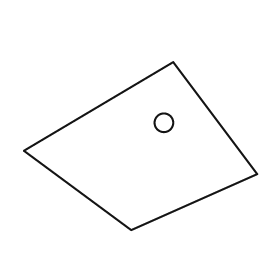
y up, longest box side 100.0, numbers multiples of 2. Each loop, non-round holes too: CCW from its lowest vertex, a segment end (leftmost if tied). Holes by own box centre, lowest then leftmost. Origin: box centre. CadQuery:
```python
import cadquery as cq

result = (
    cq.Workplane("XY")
    .moveTo(-4.0, -36.0)
    .lineTo(50.0, -12.0)
    .lineTo(14.0, 36.0)
    .lineTo(-50.0, -2.0)
    .close()
    .moveTo(10.0, 10.0)
    .circle(4.0)
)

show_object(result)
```